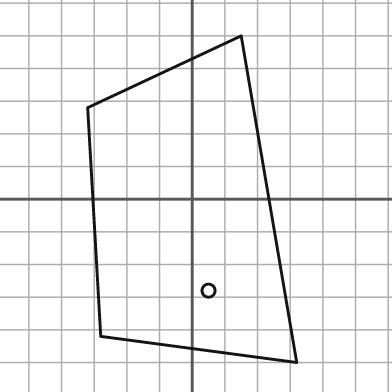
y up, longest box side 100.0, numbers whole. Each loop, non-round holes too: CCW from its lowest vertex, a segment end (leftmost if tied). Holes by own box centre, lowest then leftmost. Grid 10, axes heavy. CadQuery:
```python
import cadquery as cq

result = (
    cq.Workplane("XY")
    .moveTo(32.0, -50.0)
    .lineTo(15.0, 50.0)
    .lineTo(-32.0, 28.0)
    .lineTo(-28.0, -42.0)
    .close()
    .moveTo(5.0, -28.0)
    .circle(2.0)
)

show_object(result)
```